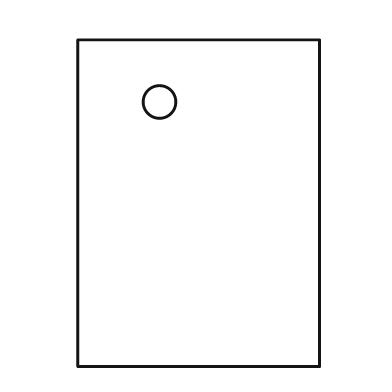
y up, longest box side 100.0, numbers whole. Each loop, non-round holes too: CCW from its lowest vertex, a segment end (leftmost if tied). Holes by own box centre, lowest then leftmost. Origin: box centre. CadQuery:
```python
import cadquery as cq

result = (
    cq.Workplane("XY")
    .moveTo(-37.0, -50.0)
    .lineTo(37.0, -50.0)
    .lineTo(37.0, 50.0)
    .lineTo(-37.0, 50.0)
    .close()
    .moveTo(-12.0, 31.0)
    .circle(5.0)
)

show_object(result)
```